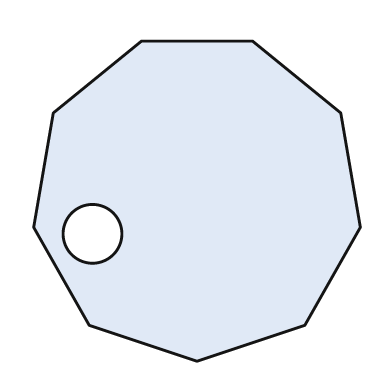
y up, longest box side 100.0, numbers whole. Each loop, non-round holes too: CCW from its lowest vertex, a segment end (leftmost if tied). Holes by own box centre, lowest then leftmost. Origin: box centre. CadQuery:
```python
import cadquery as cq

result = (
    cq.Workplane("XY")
    .moveTo(0.0, -49.0)
    .lineTo(33.0, -38.0)
    .lineTo(50.0, -8.0)
    .lineTo(44.0, 27.0)
    .lineTo(17.0, 49.0)
    .lineTo(-17.0, 49.0)
    .lineTo(-44.0, 27.0)
    .lineTo(-50.0, -8.0)
    .lineTo(-33.0, -38.0)
    .close()
    .moveTo(-32.0, -10.0)
    .circle(9.0)
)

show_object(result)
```